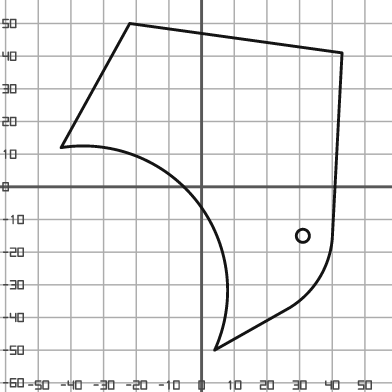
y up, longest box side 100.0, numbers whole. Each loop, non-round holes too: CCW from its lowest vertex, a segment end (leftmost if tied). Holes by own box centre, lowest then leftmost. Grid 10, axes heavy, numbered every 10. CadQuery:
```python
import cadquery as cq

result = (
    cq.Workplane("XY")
    .moveTo(4.0, -50.0)
    .lineTo(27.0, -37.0)
    .threePointArc((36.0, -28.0), (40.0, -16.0))
    .lineTo(43.0, 41.0)
    .lineTo(-22.0, 50.0)
    .lineTo(-43.0, 12.0)
    .threePointArc((-1.0, -5.0), (4.0, -50.0))
    .close()
    .moveTo(31.0, -15.0)
    .circle(2.0)
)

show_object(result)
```